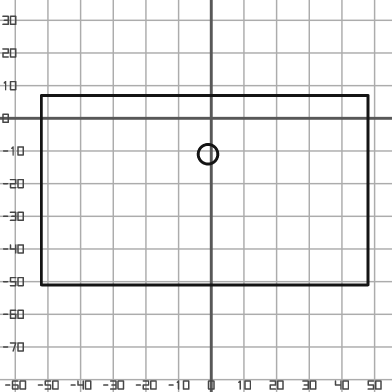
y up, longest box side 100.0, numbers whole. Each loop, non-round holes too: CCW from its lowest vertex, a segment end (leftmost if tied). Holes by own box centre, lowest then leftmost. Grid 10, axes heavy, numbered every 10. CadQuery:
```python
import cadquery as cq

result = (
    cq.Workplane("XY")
    .moveTo(-52.0, -51.0)
    .lineTo(48.0, -51.0)
    .lineTo(48.0, 7.0)
    .lineTo(-52.0, 7.0)
    .close()
    .moveTo(-1.0, -11.0)
    .circle(3.0)
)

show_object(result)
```